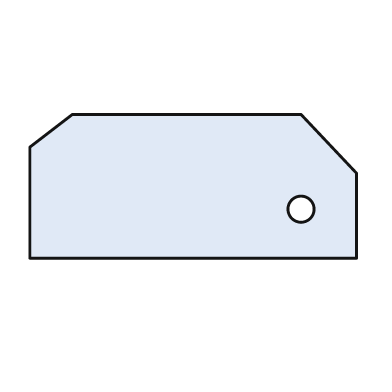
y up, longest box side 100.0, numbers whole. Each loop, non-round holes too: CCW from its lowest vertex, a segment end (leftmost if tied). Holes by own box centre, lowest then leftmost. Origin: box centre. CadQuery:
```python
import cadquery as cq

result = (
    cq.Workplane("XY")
    .moveTo(-50.0, -22.0)
    .lineTo(50.0, -22.0)
    .lineTo(50.0, 4.0)
    .lineTo(33.0, 22.0)
    .lineTo(-37.0, 22.0)
    .lineTo(-50.0, 12.0)
    .close()
    .moveTo(33.0, -7.0)
    .circle(4.0)
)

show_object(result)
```